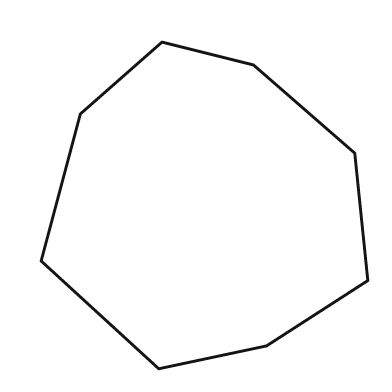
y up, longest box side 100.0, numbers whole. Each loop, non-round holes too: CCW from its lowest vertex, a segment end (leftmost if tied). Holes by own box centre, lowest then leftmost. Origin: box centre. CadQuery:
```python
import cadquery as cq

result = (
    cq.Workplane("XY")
    .moveTo(-14.0, -50.0)
    .lineTo(19.0, -43.0)
    .lineTo(50.0, -23.0)
    .lineTo(46.0, 16.0)
    .lineTo(15.0, 43.0)
    .lineTo(-13.0, 50.0)
    .lineTo(-38.0, 28.0)
    .lineTo(-50.0, -17.0)
    .close()
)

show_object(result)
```